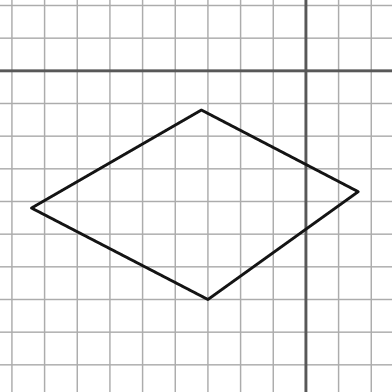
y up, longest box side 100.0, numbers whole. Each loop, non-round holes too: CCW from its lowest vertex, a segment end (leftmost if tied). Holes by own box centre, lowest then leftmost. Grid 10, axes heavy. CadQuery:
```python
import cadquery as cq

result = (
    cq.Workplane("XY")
    .moveTo(-30.0, -70.0)
    .lineTo(16.0, -37.0)
    .lineTo(-32.0, -12.0)
    .lineTo(-84.0, -42.0)
    .close()
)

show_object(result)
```